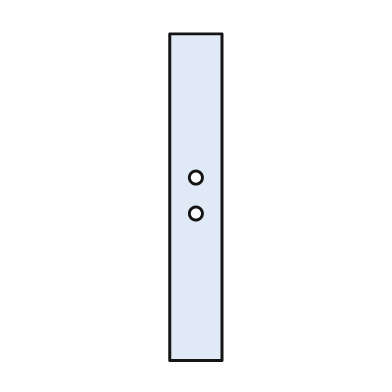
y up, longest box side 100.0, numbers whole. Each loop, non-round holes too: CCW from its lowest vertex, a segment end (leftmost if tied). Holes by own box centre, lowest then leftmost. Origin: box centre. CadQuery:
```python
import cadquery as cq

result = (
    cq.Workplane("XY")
    .moveTo(-8.0, -50.0)
    .lineTo(8.0, -50.0)
    .lineTo(8.0, 50.0)
    .lineTo(-8.0, 50.0)
    .close()
    .moveTo(0.0, -5.0)
    .circle(2.0)
    .moveTo(0.0, 6.0)
    .circle(2.0)
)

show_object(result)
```